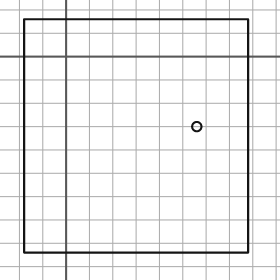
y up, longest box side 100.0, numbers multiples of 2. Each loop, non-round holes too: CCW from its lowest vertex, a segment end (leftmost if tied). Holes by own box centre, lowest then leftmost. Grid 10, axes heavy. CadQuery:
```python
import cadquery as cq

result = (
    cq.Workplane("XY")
    .moveTo(-18.0, -84.0)
    .lineTo(78.0, -84.0)
    .lineTo(78.0, 16.0)
    .lineTo(-18.0, 16.0)
    .close()
    .moveTo(56.0, -30.0)
    .circle(2.0)
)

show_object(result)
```